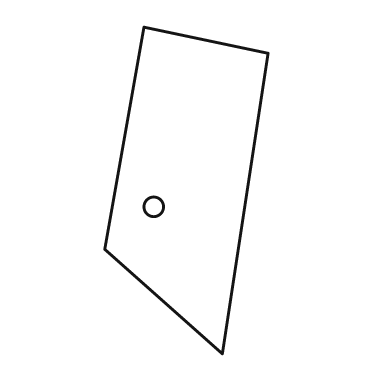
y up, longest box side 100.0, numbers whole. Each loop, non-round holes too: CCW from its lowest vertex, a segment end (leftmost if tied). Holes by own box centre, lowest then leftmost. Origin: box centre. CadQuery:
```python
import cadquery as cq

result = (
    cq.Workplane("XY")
    .moveTo(11.0, -50.0)
    .lineTo(25.0, 42.0)
    .lineTo(-13.0, 50.0)
    .lineTo(-25.0, -18.0)
    .close()
    .moveTo(-10.0, -5.0)
    .circle(3.0)
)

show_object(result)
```